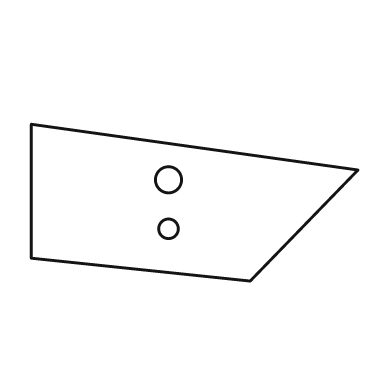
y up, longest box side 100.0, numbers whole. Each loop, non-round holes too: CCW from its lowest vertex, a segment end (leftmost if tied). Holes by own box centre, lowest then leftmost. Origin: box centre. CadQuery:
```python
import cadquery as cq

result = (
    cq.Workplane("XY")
    .moveTo(17.0, -24.0)
    .lineTo(50.0, 10.0)
    .lineTo(-50.0, 24.0)
    .lineTo(-50.0, -17.0)
    .close()
    .moveTo(-8.0, -8.0)
    .circle(3.0)
    .moveTo(-8.0, 7.0)
    .circle(4.0)
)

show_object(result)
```